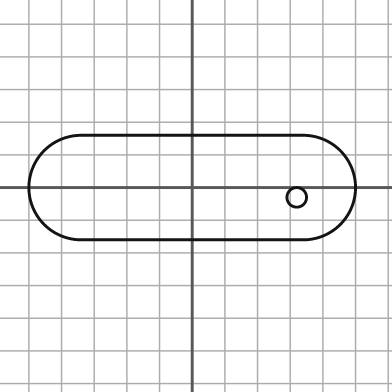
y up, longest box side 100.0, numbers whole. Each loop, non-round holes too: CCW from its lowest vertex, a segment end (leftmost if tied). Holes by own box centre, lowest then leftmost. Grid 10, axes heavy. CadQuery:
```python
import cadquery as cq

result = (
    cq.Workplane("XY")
    .moveTo(-34.0, -16.0)
    .lineTo(34.0, -16.0)
    .threePointArc((50.0, 0.0), (34.0, 16.0))
    .lineTo(-34.0, 16.0)
    .threePointArc((-50.0, 0.0), (-34.0, -16.0))
    .close()
    .moveTo(32.0, -3.0)
    .circle(3.0)
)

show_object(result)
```